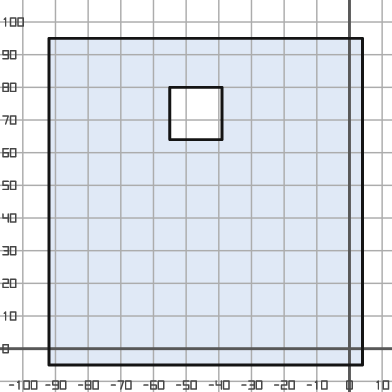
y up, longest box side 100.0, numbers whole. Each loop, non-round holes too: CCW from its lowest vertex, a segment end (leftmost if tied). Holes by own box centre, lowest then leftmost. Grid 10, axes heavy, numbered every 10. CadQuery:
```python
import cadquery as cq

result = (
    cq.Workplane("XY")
    .moveTo(-92.0, -5.0)
    .lineTo(4.0, -5.0)
    .lineTo(4.0, 95.0)
    .lineTo(-92.0, 95.0)
    .close()
    .moveTo(-55.0, 64.0)
    .lineTo(-39.0, 64.0)
    .lineTo(-39.0, 80.0)
    .lineTo(-55.0, 80.0)
    .close()
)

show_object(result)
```